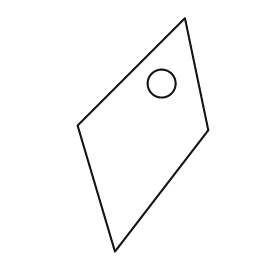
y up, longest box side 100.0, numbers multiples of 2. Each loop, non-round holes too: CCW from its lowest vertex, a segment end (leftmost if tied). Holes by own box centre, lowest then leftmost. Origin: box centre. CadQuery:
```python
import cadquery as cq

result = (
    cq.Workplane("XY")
    .moveTo(-12.0, -50.0)
    .lineTo(28.0, 2.0)
    .lineTo(18.0, 50.0)
    .lineTo(-28.0, 4.0)
    .close()
    .moveTo(8.0, 22.0)
    .circle(6.0)
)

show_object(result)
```